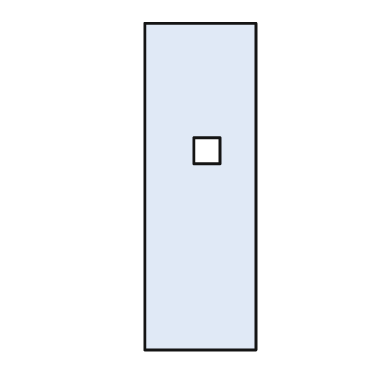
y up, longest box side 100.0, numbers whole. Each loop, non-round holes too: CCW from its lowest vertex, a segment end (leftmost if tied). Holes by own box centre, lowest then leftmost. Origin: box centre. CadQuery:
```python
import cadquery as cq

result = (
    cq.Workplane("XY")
    .moveTo(-17.0, -50.0)
    .lineTo(17.0, -50.0)
    .lineTo(17.0, 50.0)
    .lineTo(-17.0, 50.0)
    .close()
    .moveTo(-2.0, 7.0)
    .lineTo(6.0, 7.0)
    .lineTo(6.0, 15.0)
    .lineTo(-2.0, 15.0)
    .close()
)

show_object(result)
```